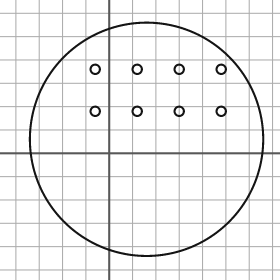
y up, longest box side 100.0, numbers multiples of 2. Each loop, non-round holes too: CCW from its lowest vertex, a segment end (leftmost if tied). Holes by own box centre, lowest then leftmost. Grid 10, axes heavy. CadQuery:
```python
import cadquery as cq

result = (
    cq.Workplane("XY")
    .moveTo(16.0, 6.0)
    .circle(50.0)
    .moveTo(-6.0, 18.0)
    .circle(2.0)
    .moveTo(12.0, 18.0)
    .circle(2.0)
    .moveTo(30.0, 18.0)
    .circle(2.0)
    .moveTo(48.0, 18.0)
    .circle(2.0)
    .moveTo(-6.0, 36.0)
    .circle(2.0)
    .moveTo(12.0, 36.0)
    .circle(2.0)
    .moveTo(30.0, 36.0)
    .circle(2.0)
    .moveTo(48.0, 36.0)
    .circle(2.0)
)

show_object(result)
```